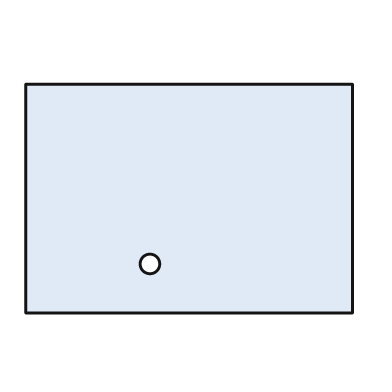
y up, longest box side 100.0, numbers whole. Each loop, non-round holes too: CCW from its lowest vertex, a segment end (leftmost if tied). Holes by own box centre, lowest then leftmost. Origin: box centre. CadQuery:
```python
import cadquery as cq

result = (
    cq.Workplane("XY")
    .moveTo(-50.0, -35.0)
    .lineTo(50.0, -35.0)
    .lineTo(50.0, 35.0)
    .lineTo(-50.0, 35.0)
    .close()
    .moveTo(-12.0, -20.0)
    .circle(3.0)
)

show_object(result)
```